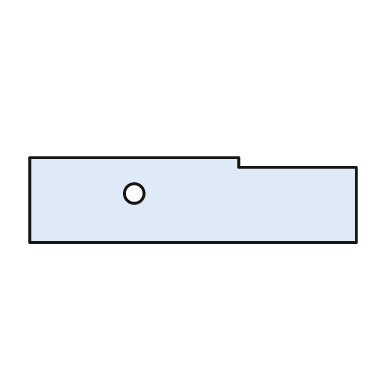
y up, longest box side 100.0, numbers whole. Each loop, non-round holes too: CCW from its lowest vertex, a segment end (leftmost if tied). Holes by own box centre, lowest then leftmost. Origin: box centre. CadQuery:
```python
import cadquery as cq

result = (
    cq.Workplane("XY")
    .moveTo(-50.0, -13.0)
    .lineTo(50.0, -13.0)
    .lineTo(50.0, 10.0)
    .lineTo(14.0, 10.0)
    .lineTo(14.0, 13.0)
    .lineTo(-50.0, 13.0)
    .close()
    .moveTo(-18.0, 2.0)
    .circle(3.0)
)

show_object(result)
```